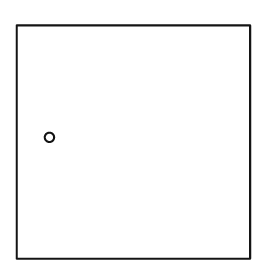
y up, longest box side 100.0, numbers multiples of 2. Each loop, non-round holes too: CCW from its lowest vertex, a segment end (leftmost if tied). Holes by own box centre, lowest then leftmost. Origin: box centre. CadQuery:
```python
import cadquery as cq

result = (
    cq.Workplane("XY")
    .moveTo(-50.0, -50.0)
    .lineTo(50.0, -50.0)
    .lineTo(50.0, 50.0)
    .lineTo(-50.0, 50.0)
    .close()
    .moveTo(-36.0, 2.0)
    .circle(2.0)
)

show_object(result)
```